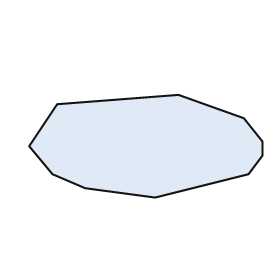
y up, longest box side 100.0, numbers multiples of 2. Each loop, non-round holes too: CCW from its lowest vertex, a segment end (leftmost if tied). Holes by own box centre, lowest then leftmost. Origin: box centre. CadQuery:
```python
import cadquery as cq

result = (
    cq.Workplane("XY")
    .moveTo(4.0, -22.0)
    .lineTo(44.0, -12.0)
    .lineTo(50.0, -4.0)
    .lineTo(50.0, 2.0)
    .lineTo(42.0, 12.0)
    .lineTo(14.0, 22.0)
    .lineTo(-38.0, 18.0)
    .lineTo(-50.0, 0.0)
    .lineTo(-40.0, -12.0)
    .lineTo(-26.0, -18.0)
    .close()
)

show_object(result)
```